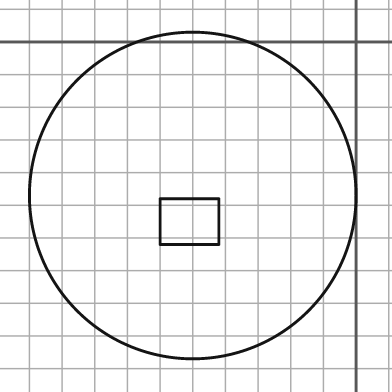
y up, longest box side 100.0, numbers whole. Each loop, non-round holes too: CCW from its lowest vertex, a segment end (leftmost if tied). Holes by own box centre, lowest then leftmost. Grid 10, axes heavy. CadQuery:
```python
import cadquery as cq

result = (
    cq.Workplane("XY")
    .moveTo(-50.0, -47.0)
    .circle(50.0)
    .moveTo(-60.0, -62.0)
    .lineTo(-42.0, -62.0)
    .lineTo(-42.0, -48.0)
    .lineTo(-60.0, -48.0)
    .close()
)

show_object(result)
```